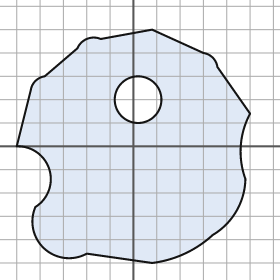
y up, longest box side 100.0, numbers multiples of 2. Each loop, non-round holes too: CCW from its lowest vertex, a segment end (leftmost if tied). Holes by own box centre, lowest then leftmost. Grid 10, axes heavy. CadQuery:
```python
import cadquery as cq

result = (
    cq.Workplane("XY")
    .moveTo(8.0, -50.0)
    .threePointArc((22.0, -46.0), (34.0, -38.0))
    .threePointArc((44.0, -28.0), (48.0, -14.0))
    .threePointArc((46.0, 0.0), (50.0, 14.0))
    .lineTo(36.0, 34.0)
    .threePointArc((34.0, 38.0), (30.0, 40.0))
    .lineTo(8.0, 50.0)
    .lineTo(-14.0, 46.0)
    .threePointArc((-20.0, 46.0), (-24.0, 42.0))
    .lineTo(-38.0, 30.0)
    .threePointArc((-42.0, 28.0), (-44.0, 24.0))
    .lineTo(-50.0, 0.0)
    .threePointArc((-36.0, -10.0), (-42.0, -26.0))
    .threePointArc((-38.0, -44.0), (-20.0, -46.0))
    .close()
    .moveTo(2.0, 20.0)
    .circle(10.0)
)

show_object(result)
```